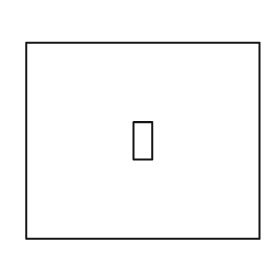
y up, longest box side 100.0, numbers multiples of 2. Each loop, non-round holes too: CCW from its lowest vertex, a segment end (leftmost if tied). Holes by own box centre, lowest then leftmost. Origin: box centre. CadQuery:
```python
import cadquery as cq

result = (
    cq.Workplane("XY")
    .moveTo(-50.0, -42.0)
    .lineTo(50.0, -42.0)
    .lineTo(50.0, 42.0)
    .lineTo(-50.0, 42.0)
    .close()
    .moveTo(-4.0, -8.0)
    .lineTo(4.0, -8.0)
    .lineTo(4.0, 8.0)
    .lineTo(-4.0, 8.0)
    .close()
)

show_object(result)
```